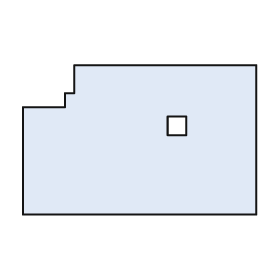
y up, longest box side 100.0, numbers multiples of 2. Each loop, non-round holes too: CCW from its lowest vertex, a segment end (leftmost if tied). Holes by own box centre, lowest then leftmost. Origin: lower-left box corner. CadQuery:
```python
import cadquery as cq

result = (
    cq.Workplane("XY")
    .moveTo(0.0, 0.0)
    .lineTo(100.0, 0.0)
    .lineTo(100.0, 64.0)
    .lineTo(22.0, 64.0)
    .lineTo(22.0, 52.0)
    .lineTo(18.0, 52.0)
    .lineTo(18.0, 46.0)
    .lineTo(0.0, 46.0)
    .close()
    .moveTo(62.0, 34.0)
    .lineTo(70.0, 34.0)
    .lineTo(70.0, 42.0)
    .lineTo(62.0, 42.0)
    .close()
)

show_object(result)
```